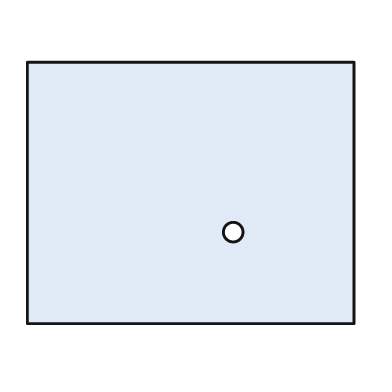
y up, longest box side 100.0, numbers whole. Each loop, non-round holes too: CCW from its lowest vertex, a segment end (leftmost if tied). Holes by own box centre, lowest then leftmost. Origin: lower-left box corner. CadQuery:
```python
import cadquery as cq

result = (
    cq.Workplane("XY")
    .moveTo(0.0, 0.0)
    .lineTo(100.0, 0.0)
    .lineTo(100.0, 80.0)
    .lineTo(0.0, 80.0)
    .close()
    .moveTo(63.0, 28.0)
    .circle(3.0)
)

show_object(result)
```